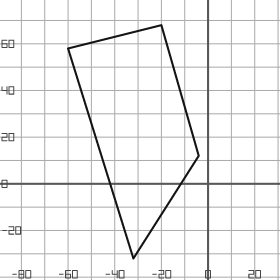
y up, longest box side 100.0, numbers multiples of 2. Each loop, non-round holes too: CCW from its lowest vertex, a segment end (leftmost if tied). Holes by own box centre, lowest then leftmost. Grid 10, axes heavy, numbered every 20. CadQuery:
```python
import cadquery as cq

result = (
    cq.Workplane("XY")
    .moveTo(-32.0, -32.0)
    .lineTo(-4.0, 12.0)
    .lineTo(-20.0, 68.0)
    .lineTo(-60.0, 58.0)
    .close()
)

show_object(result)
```